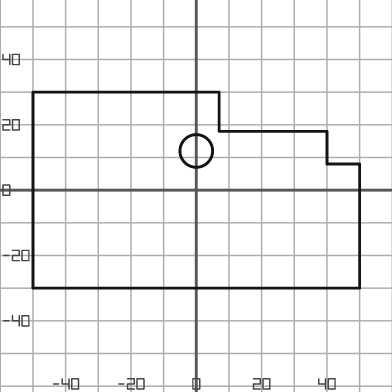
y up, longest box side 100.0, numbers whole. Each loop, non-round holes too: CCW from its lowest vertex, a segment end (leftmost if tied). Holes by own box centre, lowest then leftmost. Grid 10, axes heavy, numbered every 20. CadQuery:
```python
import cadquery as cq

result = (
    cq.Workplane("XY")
    .moveTo(-50.0, -30.0)
    .lineTo(50.0, -30.0)
    .lineTo(50.0, 8.0)
    .lineTo(40.0, 8.0)
    .lineTo(40.0, 18.0)
    .lineTo(7.0, 18.0)
    .lineTo(7.0, 30.0)
    .lineTo(-50.0, 30.0)
    .close()
    .moveTo(0.0, 12.0)
    .circle(5.0)
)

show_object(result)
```